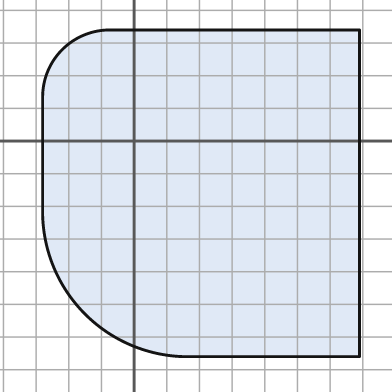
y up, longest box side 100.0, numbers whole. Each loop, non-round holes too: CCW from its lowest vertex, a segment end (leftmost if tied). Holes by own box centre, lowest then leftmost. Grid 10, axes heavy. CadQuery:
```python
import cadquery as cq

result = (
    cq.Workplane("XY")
    .moveTo(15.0, -66.0)
    .lineTo(69.0, -66.0)
    .lineTo(69.0, 34.0)
    .lineTo(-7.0, 34.0)
    .threePointArc((-22.0, 28.0), (-28.0, 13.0))
    .lineTo(-28.0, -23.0)
    .threePointArc((-15.0, -53.0), (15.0, -66.0))
    .close()
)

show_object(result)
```